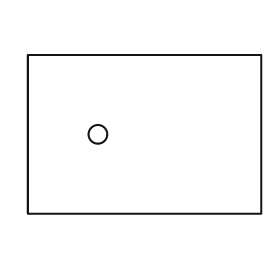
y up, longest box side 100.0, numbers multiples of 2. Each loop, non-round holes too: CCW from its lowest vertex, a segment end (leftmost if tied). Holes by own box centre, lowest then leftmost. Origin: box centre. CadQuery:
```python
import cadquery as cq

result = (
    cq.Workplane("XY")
    .moveTo(-50.0, -34.0)
    .lineTo(50.0, -34.0)
    .lineTo(50.0, 34.0)
    .lineTo(-50.0, 34.0)
    .close()
    .moveTo(-20.0, 0.0)
    .circle(4.0)
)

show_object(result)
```